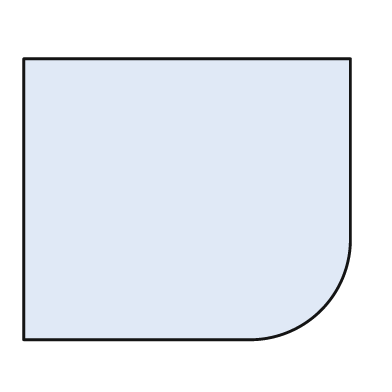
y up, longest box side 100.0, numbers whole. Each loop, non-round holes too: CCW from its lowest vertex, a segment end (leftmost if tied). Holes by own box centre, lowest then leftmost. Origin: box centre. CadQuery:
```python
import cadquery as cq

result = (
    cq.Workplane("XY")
    .moveTo(-50.0, -43.0)
    .lineTo(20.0, -43.0)
    .threePointArc((41.0, -34.0), (50.0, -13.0))
    .lineTo(50.0, 43.0)
    .lineTo(-50.0, 43.0)
    .close()
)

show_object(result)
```